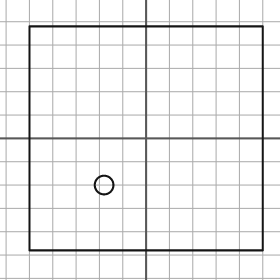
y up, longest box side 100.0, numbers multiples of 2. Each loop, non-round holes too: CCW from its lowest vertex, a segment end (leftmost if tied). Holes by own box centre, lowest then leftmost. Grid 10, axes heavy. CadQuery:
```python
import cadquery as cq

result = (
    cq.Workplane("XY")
    .moveTo(-50.0, -48.0)
    .lineTo(50.0, -48.0)
    .lineTo(50.0, 48.0)
    .lineTo(-50.0, 48.0)
    .close()
    .moveTo(-18.0, -20.0)
    .circle(4.0)
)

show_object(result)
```